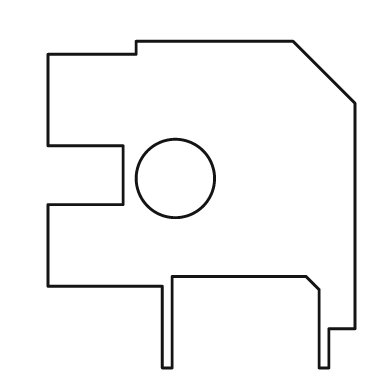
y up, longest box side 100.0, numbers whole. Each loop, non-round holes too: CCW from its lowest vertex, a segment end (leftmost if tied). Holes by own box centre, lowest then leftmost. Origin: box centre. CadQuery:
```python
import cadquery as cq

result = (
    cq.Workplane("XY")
    .moveTo(-12.0, -50.0)
    .lineTo(-9.0, -50.0)
    .lineTo(-9.0, -22.0)
    .lineTo(32.0, -22.0)
    .lineTo(36.0, -26.0)
    .lineTo(36.0, -50.0)
    .lineTo(39.0, -50.0)
    .lineTo(39.0, -38.0)
    .lineTo(47.0, -38.0)
    .lineTo(47.0, 31.0)
    .lineTo(28.0, 50.0)
    .lineTo(-20.0, 50.0)
    .lineTo(-20.0, 46.0)
    .lineTo(-47.0, 46.0)
    .lineTo(-47.0, 18.0)
    .lineTo(-24.0, 18.0)
    .lineTo(-24.0, 0.0)
    .lineTo(-47.0, 0.0)
    .lineTo(-47.0, -25.0)
    .lineTo(-12.0, -25.0)
    .close()
    .moveTo(-8.0, 8.0)
    .circle(12.0)
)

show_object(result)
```